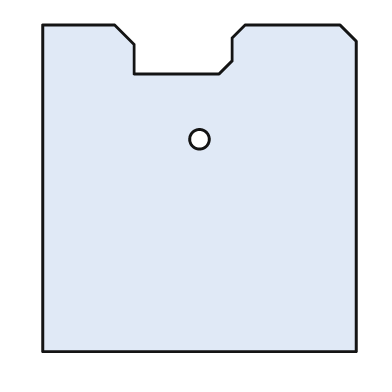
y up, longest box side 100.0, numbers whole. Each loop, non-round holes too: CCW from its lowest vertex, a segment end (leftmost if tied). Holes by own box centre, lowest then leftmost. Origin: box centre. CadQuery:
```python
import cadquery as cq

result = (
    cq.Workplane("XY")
    .moveTo(-48.0, -50.0)
    .lineTo(48.0, -50.0)
    .lineTo(48.0, 45.0)
    .lineTo(43.0, 50.0)
    .lineTo(14.0, 50.0)
    .lineTo(10.0, 46.0)
    .lineTo(10.0, 39.0)
    .lineTo(6.0, 35.0)
    .lineTo(-20.0, 35.0)
    .lineTo(-20.0, 44.0)
    .lineTo(-26.0, 50.0)
    .lineTo(-48.0, 50.0)
    .close()
    .moveTo(0.0, 15.0)
    .circle(3.0)
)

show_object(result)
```